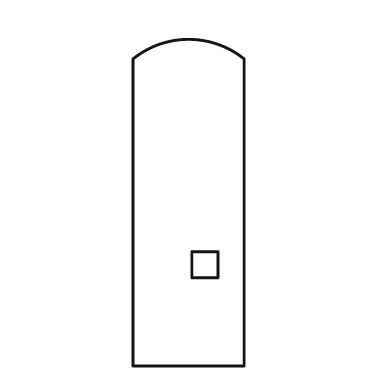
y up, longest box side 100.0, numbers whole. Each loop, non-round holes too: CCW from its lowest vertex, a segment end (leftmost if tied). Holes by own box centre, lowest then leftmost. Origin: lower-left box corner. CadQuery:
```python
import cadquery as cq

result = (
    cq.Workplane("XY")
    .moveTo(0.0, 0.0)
    .lineTo(34.0, 0.0)
    .lineTo(34.0, 94.0)
    .threePointArc((17.0, 100.0), (0.0, 94.0))
    .close()
    .moveTo(18.0, 27.0)
    .lineTo(26.0, 27.0)
    .lineTo(26.0, 35.0)
    .lineTo(18.0, 35.0)
    .close()
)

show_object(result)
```